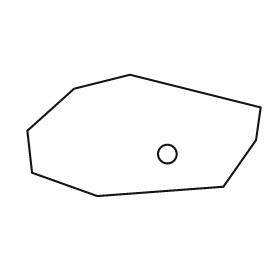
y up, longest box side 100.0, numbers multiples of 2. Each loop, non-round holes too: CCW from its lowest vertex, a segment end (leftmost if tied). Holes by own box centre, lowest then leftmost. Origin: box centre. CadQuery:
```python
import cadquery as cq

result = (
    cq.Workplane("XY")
    .moveTo(-20.0, -26.0)
    .lineTo(34.0, -22.0)
    .lineTo(48.0, -2.0)
    .lineTo(50.0, 12.0)
    .lineTo(-6.0, 26.0)
    .lineTo(-30.0, 20.0)
    .lineTo(-50.0, 2.0)
    .lineTo(-48.0, -16.0)
    .close()
    .moveTo(10.0, -8.0)
    .circle(4.0)
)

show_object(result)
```